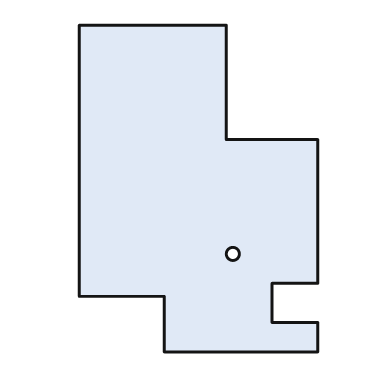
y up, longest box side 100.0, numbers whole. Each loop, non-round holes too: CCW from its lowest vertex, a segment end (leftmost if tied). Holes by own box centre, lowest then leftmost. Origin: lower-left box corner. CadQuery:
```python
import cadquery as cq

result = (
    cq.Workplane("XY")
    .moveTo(26.0, 0.0)
    .lineTo(73.0, 0.0)
    .lineTo(73.0, 9.0)
    .lineTo(59.0, 9.0)
    .lineTo(59.0, 21.0)
    .lineTo(73.0, 21.0)
    .lineTo(73.0, 65.0)
    .lineTo(45.0, 65.0)
    .lineTo(45.0, 100.0)
    .lineTo(0.0, 100.0)
    .lineTo(0.0, 17.0)
    .lineTo(26.0, 17.0)
    .close()
    .moveTo(47.0, 30.0)
    .circle(2.0)
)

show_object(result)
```